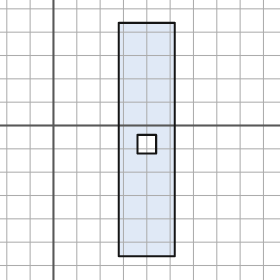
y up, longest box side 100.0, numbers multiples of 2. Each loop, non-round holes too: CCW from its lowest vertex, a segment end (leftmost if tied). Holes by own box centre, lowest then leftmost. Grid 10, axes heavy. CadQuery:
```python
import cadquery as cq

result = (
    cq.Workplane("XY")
    .moveTo(28.0, -56.0)
    .lineTo(52.0, -56.0)
    .lineTo(52.0, 44.0)
    .lineTo(28.0, 44.0)
    .close()
    .moveTo(36.0, -12.0)
    .lineTo(44.0, -12.0)
    .lineTo(44.0, -4.0)
    .lineTo(36.0, -4.0)
    .close()
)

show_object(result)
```